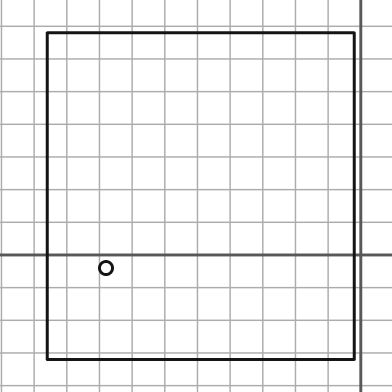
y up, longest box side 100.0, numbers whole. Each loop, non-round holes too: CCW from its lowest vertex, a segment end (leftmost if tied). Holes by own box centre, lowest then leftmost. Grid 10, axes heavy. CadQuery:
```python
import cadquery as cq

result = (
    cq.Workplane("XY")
    .moveTo(-96.0, -32.0)
    .lineTo(-2.0, -32.0)
    .lineTo(-2.0, 68.0)
    .lineTo(-96.0, 68.0)
    .close()
    .moveTo(-78.0, -4.0)
    .circle(2.0)
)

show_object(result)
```